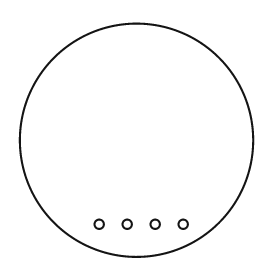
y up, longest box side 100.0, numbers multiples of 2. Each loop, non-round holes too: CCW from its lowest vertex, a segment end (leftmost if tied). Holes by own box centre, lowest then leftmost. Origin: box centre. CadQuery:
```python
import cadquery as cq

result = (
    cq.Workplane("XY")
    .moveTo(0.0, 0.0)
    .circle(50.0)
    .moveTo(-16.0, -36.0)
    .circle(2.0)
    .moveTo(-4.0, -36.0)
    .circle(2.0)
    .moveTo(8.0, -36.0)
    .circle(2.0)
    .moveTo(20.0, -36.0)
    .circle(2.0)
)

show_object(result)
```